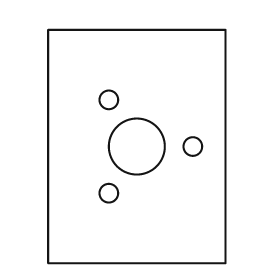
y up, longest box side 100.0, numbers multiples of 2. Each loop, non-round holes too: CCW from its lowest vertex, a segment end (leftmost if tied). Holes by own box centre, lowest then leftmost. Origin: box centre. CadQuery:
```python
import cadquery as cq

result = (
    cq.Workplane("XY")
    .moveTo(-38.0, -50.0)
    .lineTo(38.0, -50.0)
    .lineTo(38.0, 50.0)
    .lineTo(-38.0, 50.0)
    .close()
    .moveTo(-12.0, -20.0)
    .circle(4.0)
    .moveTo(0.0, 0.0)
    .circle(12.0)
    .moveTo(24.0, 0.0)
    .circle(4.0)
    .moveTo(-12.0, 20.0)
    .circle(4.0)
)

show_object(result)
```